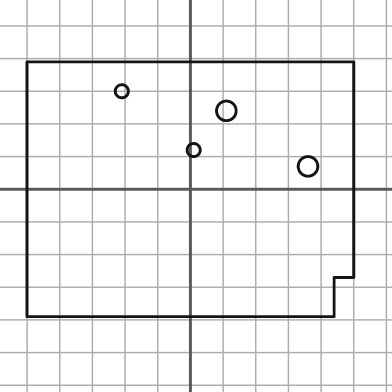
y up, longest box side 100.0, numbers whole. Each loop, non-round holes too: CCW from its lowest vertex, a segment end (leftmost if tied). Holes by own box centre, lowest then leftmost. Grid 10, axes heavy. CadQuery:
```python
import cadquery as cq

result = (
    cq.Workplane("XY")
    .moveTo(-50.0, -39.0)
    .lineTo(44.0, -39.0)
    .lineTo(44.0, -27.0)
    .lineTo(50.0, -27.0)
    .lineTo(50.0, 39.0)
    .lineTo(-50.0, 39.0)
    .close()
    .moveTo(36.0, 7.0)
    .circle(3.0)
    .moveTo(1.0, 12.0)
    .circle(2.0)
    .moveTo(11.0, 24.0)
    .circle(3.0)
    .moveTo(-21.0, 30.0)
    .circle(2.0)
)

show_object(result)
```